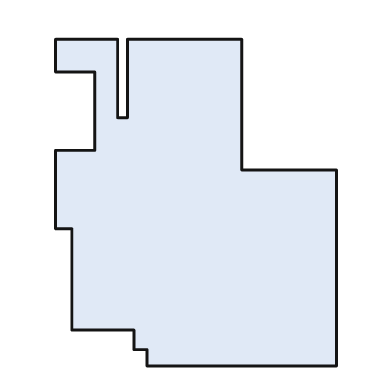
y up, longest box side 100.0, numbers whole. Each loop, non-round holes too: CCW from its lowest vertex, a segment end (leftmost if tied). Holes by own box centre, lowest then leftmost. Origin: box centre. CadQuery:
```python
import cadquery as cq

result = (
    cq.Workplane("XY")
    .moveTo(-15.0, -50.0)
    .lineTo(43.0, -50.0)
    .lineTo(43.0, 10.0)
    .lineTo(14.0, 10.0)
    .lineTo(14.0, 50.0)
    .lineTo(-21.0, 50.0)
    .lineTo(-21.0, 26.0)
    .lineTo(-24.0, 26.0)
    .lineTo(-24.0, 50.0)
    .lineTo(-43.0, 50.0)
    .lineTo(-43.0, 40.0)
    .lineTo(-31.0, 40.0)
    .lineTo(-31.0, 16.0)
    .lineTo(-43.0, 16.0)
    .lineTo(-43.0, -8.0)
    .lineTo(-38.0, -8.0)
    .lineTo(-38.0, -39.0)
    .lineTo(-19.0, -39.0)
    .lineTo(-19.0, -45.0)
    .lineTo(-15.0, -45.0)
    .close()
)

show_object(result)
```